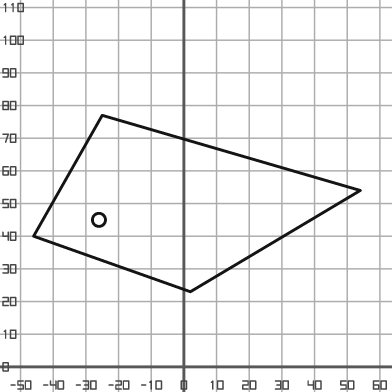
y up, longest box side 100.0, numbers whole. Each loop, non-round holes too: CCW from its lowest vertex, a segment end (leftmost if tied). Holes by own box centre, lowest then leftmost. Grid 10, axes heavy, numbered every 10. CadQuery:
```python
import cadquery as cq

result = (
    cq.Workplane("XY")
    .moveTo(2.0, 23.0)
    .lineTo(54.0, 54.0)
    .lineTo(-25.0, 77.0)
    .lineTo(-46.0, 40.0)
    .close()
    .moveTo(-26.0, 45.0)
    .circle(2.0)
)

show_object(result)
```